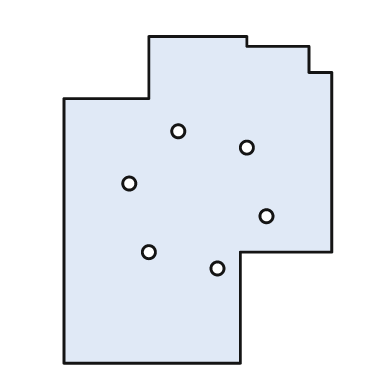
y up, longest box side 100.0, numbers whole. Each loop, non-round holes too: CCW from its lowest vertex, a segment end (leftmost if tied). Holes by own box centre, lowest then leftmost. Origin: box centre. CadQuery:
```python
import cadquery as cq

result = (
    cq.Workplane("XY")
    .moveTo(-41.0, -50.0)
    .lineTo(13.0, -50.0)
    .lineTo(13.0, -16.0)
    .lineTo(41.0, -16.0)
    .lineTo(41.0, 39.0)
    .lineTo(34.0, 39.0)
    .lineTo(34.0, 47.0)
    .lineTo(15.0, 47.0)
    .lineTo(15.0, 50.0)
    .lineTo(-15.0, 50.0)
    .lineTo(-15.0, 31.0)
    .lineTo(-41.0, 31.0)
    .close()
    .moveTo(6.0, -21.0)
    .circle(2.0)
    .moveTo(-15.0, -16.0)
    .circle(2.0)
    .moveTo(21.0, -5.0)
    .circle(2.0)
    .moveTo(-21.0, 5.0)
    .circle(2.0)
    .moveTo(15.0, 16.0)
    .circle(2.0)
    .moveTo(-6.0, 21.0)
    .circle(2.0)
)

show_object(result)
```